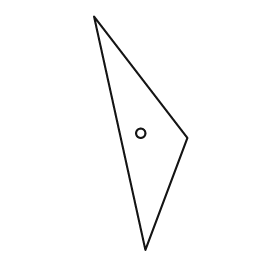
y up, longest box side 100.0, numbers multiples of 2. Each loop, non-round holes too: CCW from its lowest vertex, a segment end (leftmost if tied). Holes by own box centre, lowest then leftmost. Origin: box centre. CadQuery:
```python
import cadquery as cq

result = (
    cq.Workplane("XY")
    .moveTo(2.0, -50.0)
    .lineTo(20.0, -2.0)
    .lineTo(-20.0, 50.0)
    .close()
    .moveTo(0.0, 0.0)
    .circle(2.0)
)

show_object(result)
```